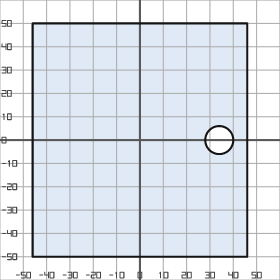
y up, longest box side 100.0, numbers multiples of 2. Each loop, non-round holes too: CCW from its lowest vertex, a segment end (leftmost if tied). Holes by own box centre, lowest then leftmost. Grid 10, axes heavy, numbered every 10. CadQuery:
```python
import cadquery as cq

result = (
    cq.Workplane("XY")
    .moveTo(-46.0, -50.0)
    .lineTo(46.0, -50.0)
    .lineTo(46.0, 50.0)
    .lineTo(-46.0, 50.0)
    .close()
    .moveTo(34.0, 0.0)
    .circle(6.0)
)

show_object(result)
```